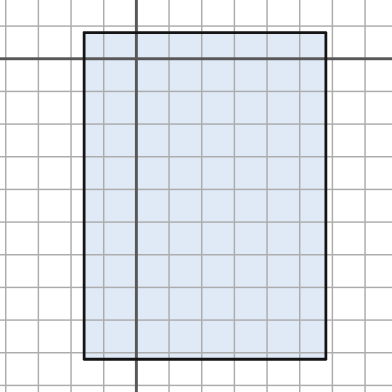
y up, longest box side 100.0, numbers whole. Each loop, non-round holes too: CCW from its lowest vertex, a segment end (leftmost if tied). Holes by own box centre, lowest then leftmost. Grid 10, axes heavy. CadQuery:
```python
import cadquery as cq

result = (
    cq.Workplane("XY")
    .moveTo(-16.0, -92.0)
    .lineTo(58.0, -92.0)
    .lineTo(58.0, 8.0)
    .lineTo(-16.0, 8.0)
    .close()
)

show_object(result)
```